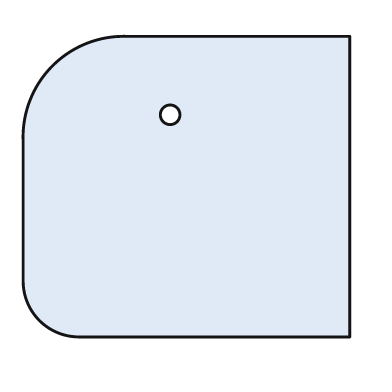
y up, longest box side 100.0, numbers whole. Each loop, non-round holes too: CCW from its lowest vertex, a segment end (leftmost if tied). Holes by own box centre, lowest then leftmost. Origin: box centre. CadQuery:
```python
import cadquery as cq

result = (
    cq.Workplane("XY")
    .moveTo(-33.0, -46.0)
    .lineTo(50.0, -46.0)
    .lineTo(50.0, 46.0)
    .lineTo(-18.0, 46.0)
    .threePointArc((-41.0, 37.0), (-50.0, 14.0))
    .lineTo(-50.0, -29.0)
    .threePointArc((-45.0, -41.0), (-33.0, -46.0))
    .close()
    .moveTo(-5.0, 22.0)
    .circle(3.0)
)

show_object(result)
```